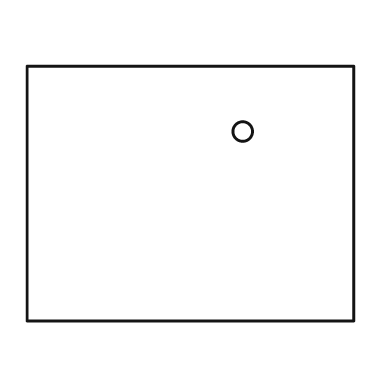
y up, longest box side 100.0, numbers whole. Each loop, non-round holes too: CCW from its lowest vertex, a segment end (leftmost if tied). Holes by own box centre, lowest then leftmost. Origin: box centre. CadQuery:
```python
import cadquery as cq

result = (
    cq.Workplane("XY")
    .moveTo(-50.0, -39.0)
    .lineTo(50.0, -39.0)
    .lineTo(50.0, 39.0)
    .lineTo(-50.0, 39.0)
    .close()
    .moveTo(16.0, 19.0)
    .circle(3.0)
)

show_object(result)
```